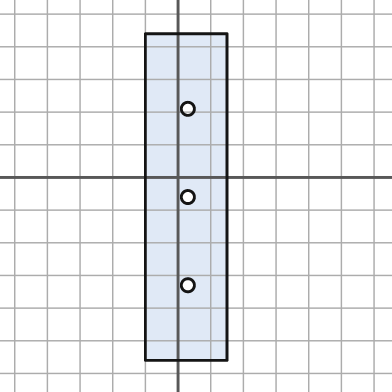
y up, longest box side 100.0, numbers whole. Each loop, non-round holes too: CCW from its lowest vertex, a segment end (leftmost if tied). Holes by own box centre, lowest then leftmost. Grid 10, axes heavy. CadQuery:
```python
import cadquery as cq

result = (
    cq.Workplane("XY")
    .moveTo(-10.0, -56.0)
    .lineTo(15.0, -56.0)
    .lineTo(15.0, 44.0)
    .lineTo(-10.0, 44.0)
    .close()
    .moveTo(3.0, -33.0)
    .circle(2.0)
    .moveTo(3.0, -6.0)
    .circle(2.0)
    .moveTo(3.0, 21.0)
    .circle(2.0)
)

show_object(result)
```